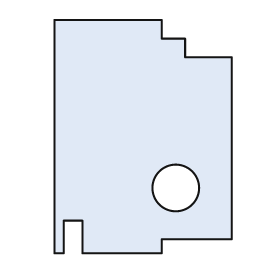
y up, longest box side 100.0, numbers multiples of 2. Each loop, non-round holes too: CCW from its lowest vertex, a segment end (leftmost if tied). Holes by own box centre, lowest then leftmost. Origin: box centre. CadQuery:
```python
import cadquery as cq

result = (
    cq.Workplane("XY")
    .moveTo(-38.0, -50.0)
    .lineTo(-34.0, -50.0)
    .lineTo(-34.0, -36.0)
    .lineTo(-26.0, -36.0)
    .lineTo(-26.0, -50.0)
    .lineTo(8.0, -50.0)
    .lineTo(8.0, -44.0)
    .lineTo(38.0, -44.0)
    .lineTo(38.0, 34.0)
    .lineTo(18.0, 34.0)
    .lineTo(18.0, 42.0)
    .lineTo(8.0, 42.0)
    .lineTo(8.0, 50.0)
    .lineTo(-38.0, 50.0)
    .close()
    .moveTo(14.0, -22.0)
    .circle(10.0)
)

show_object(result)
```